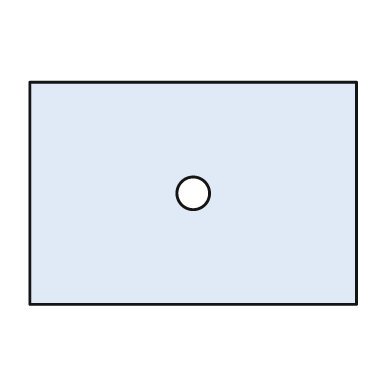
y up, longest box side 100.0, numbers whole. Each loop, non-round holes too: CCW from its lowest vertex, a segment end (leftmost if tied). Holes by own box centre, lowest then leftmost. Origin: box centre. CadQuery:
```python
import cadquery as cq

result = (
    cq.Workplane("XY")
    .moveTo(-50.0, -34.0)
    .lineTo(50.0, -34.0)
    .lineTo(50.0, 34.0)
    .lineTo(-50.0, 34.0)
    .close()
    .moveTo(0.0, 0.0)
    .circle(5.0)
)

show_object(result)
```